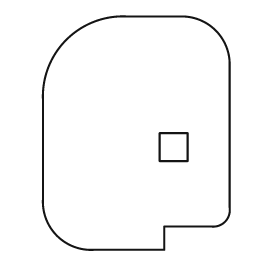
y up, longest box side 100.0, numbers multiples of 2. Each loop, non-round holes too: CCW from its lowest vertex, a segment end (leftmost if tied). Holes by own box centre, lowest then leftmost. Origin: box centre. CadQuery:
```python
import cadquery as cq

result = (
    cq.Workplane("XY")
    .moveTo(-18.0, -50.0)
    .lineTo(12.0, -50.0)
    .lineTo(12.0, -40.0)
    .lineTo(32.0, -40.0)
    .threePointArc((38.0, -38.0), (40.0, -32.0))
    .lineTo(40.0, 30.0)
    .threePointArc((34.0, 44.0), (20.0, 50.0))
    .lineTo(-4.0, 50.0)
    .threePointArc((-30.0, 40.0), (-40.0, 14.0))
    .lineTo(-40.0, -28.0)
    .threePointArc((-34.0, -44.0), (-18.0, -50.0))
    .close()
    .moveTo(10.0, -12.0)
    .lineTo(22.0, -12.0)
    .lineTo(22.0, 0.0)
    .lineTo(10.0, 0.0)
    .close()
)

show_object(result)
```